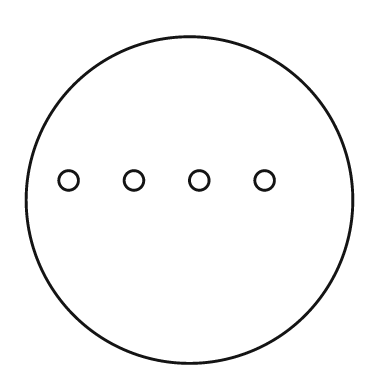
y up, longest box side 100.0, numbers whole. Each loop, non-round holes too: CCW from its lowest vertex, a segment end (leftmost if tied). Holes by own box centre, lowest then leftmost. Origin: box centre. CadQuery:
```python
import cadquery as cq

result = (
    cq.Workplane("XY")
    .moveTo(0.0, 0.0)
    .circle(50.0)
    .moveTo(-37.0, 6.0)
    .circle(3.0)
    .moveTo(-17.0, 6.0)
    .circle(3.0)
    .moveTo(3.0, 6.0)
    .circle(3.0)
    .moveTo(23.0, 6.0)
    .circle(3.0)
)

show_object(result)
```